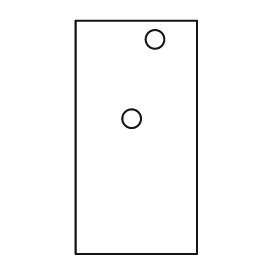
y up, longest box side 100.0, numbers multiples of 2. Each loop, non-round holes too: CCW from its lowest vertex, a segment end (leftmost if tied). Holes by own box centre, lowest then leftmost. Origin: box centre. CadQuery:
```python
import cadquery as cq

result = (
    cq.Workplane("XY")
    .moveTo(-26.0, -50.0)
    .lineTo(26.0, -50.0)
    .lineTo(26.0, 50.0)
    .lineTo(-26.0, 50.0)
    .close()
    .moveTo(-2.0, 8.0)
    .circle(4.0)
    .moveTo(8.0, 42.0)
    .circle(4.0)
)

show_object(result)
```